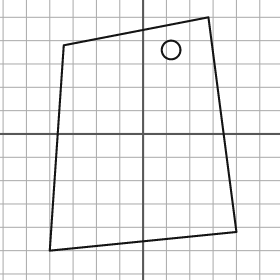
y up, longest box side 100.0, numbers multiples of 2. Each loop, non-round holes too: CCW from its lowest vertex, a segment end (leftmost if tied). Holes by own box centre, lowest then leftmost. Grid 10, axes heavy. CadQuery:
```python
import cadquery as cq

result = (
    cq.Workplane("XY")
    .moveTo(-40.0, -50.0)
    .lineTo(40.0, -42.0)
    .lineTo(28.0, 50.0)
    .lineTo(-34.0, 38.0)
    .close()
    .moveTo(12.0, 36.0)
    .circle(4.0)
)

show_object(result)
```